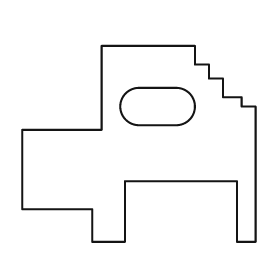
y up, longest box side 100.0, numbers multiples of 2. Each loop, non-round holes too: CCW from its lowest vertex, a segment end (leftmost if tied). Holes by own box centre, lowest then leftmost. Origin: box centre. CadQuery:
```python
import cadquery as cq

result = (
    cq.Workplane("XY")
    .moveTo(-20.0, -42.0)
    .lineTo(-6.0, -42.0)
    .lineTo(-6.0, -16.0)
    .lineTo(42.0, -16.0)
    .lineTo(42.0, -42.0)
    .lineTo(50.0, -42.0)
    .lineTo(50.0, 16.0)
    .lineTo(44.0, 16.0)
    .lineTo(44.0, 20.0)
    .lineTo(36.0, 20.0)
    .lineTo(36.0, 28.0)
    .lineTo(30.0, 28.0)
    .lineTo(30.0, 34.0)
    .lineTo(24.0, 34.0)
    .lineTo(24.0, 42.0)
    .lineTo(-16.0, 42.0)
    .lineTo(-16.0, 6.0)
    .lineTo(-50.0, 6.0)
    .lineTo(-50.0, -28.0)
    .lineTo(-20.0, -28.0)
    .close()
    .moveTo(0.0, 8.0)
    .lineTo(16.0, 8.0)
    .threePointArc((24.0, 16.0), (16.0, 24.0))
    .lineTo(0.0, 24.0)
    .threePointArc((-8.0, 16.0), (0.0, 8.0))
    .close()
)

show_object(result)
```